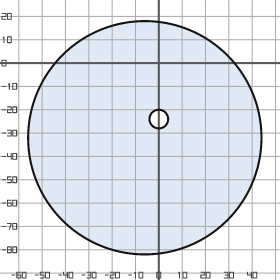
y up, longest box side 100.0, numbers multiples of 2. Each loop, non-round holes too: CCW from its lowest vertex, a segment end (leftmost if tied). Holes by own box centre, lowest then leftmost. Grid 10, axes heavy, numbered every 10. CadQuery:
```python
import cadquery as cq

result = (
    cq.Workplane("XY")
    .moveTo(-6.0, -32.0)
    .circle(50.0)
    .moveTo(0.0, -24.0)
    .circle(4.0)
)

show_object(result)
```